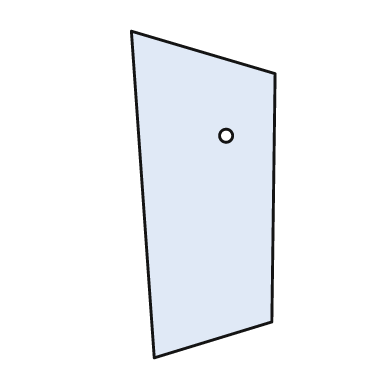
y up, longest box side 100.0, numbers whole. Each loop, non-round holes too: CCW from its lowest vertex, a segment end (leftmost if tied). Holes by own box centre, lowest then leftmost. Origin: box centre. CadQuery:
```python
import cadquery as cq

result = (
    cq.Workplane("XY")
    .moveTo(-15.0, -50.0)
    .lineTo(21.0, -39.0)
    .lineTo(22.0, 37.0)
    .lineTo(-22.0, 50.0)
    .close()
    .moveTo(7.0, 18.0)
    .circle(2.0)
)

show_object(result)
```